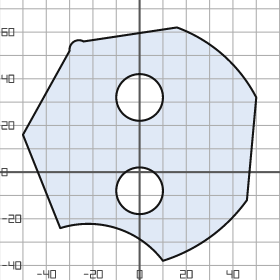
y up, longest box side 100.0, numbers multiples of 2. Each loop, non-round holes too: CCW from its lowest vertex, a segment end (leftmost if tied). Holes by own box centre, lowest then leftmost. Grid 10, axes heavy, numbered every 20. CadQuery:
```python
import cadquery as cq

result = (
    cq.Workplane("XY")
    .moveTo(10.0, -38.0)
    .threePointArc((30.0, -28.0), (46.0, -12.0))
    .lineTo(50.0, 32.0)
    .threePointArc((36.0, 50.0), (16.0, 62.0))
    .lineTo(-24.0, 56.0)
    .threePointArc((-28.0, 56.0), (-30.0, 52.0))
    .lineTo(-50.0, 16.0)
    .lineTo(-34.0, -24.0)
    .threePointArc((-10.0, -24.0), (10.0, -38.0))
    .close()
    .moveTo(0.0, -8.0)
    .circle(10.0)
    .moveTo(0.0, 32.0)
    .circle(10.0)
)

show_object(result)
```